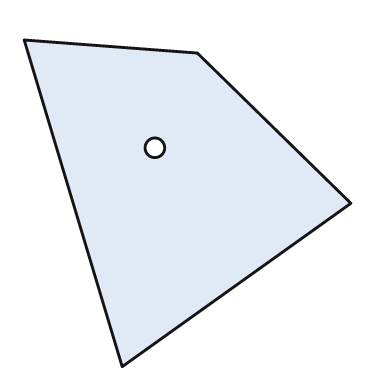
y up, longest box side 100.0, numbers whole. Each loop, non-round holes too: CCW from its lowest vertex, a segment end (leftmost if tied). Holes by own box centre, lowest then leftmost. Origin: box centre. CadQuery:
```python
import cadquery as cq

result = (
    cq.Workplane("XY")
    .moveTo(-20.0, -50.0)
    .lineTo(50.0, 0.0)
    .lineTo(3.0, 46.0)
    .lineTo(-50.0, 50.0)
    .close()
    .moveTo(-10.0, 17.0)
    .circle(3.0)
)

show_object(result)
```